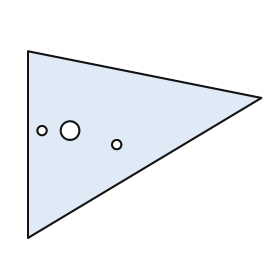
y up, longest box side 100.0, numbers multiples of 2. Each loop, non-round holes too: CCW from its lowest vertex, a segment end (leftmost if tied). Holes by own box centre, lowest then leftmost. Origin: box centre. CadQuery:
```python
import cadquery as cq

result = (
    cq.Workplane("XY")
    .moveTo(-50.0, -40.0)
    .lineTo(50.0, 20.0)
    .lineTo(-50.0, 40.0)
    .close()
    .moveTo(-12.0, 0.0)
    .circle(2.0)
    .moveTo(-44.0, 6.0)
    .circle(2.0)
    .moveTo(-32.0, 6.0)
    .circle(4.0)
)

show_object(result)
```